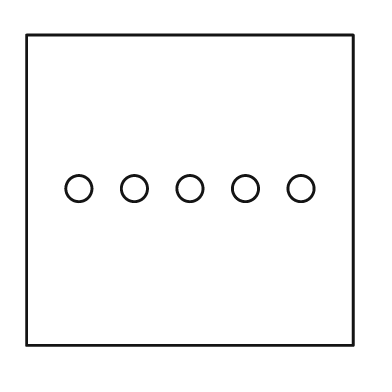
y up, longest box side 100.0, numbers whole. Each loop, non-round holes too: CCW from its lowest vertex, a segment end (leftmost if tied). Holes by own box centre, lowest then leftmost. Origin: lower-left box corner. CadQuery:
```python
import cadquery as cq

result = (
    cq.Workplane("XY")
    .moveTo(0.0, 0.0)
    .lineTo(100.0, 0.0)
    .lineTo(100.0, 95.0)
    .lineTo(0.0, 95.0)
    .close()
    .moveTo(16.0, 48.0)
    .circle(4.0)
    .moveTo(33.0, 48.0)
    .circle(4.0)
    .moveTo(50.0, 48.0)
    .circle(4.0)
    .moveTo(67.0, 48.0)
    .circle(4.0)
    .moveTo(84.0, 48.0)
    .circle(4.0)
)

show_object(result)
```